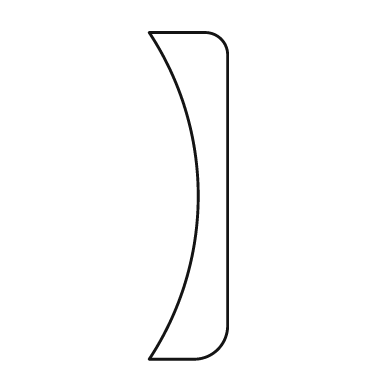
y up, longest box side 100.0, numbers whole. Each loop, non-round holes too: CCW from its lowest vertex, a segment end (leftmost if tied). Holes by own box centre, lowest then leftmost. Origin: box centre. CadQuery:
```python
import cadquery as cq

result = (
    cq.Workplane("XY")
    .moveTo(-12.0, -50.0)
    .lineTo(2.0, -50.0)
    .threePointArc((9.0, -47.0), (12.0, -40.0))
    .lineTo(12.0, 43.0)
    .threePointArc((10.0, 48.0), (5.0, 50.0))
    .lineTo(-12.0, 50.0)
    .threePointArc((3.0, 0.0), (-12.0, -50.0))
    .close()
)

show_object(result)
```